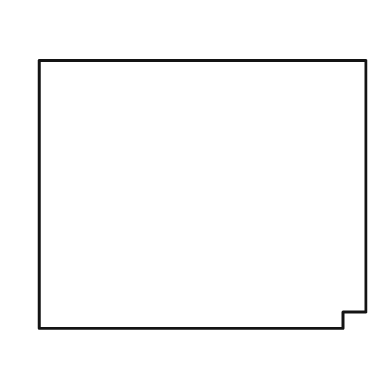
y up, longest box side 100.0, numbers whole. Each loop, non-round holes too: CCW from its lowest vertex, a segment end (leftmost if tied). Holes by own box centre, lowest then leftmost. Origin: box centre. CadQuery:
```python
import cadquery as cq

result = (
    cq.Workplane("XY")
    .moveTo(-50.0, -41.0)
    .lineTo(43.0, -41.0)
    .lineTo(43.0, -36.0)
    .lineTo(50.0, -36.0)
    .lineTo(50.0, 41.0)
    .lineTo(-50.0, 41.0)
    .close()
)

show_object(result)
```